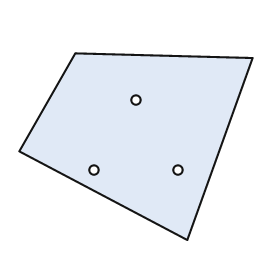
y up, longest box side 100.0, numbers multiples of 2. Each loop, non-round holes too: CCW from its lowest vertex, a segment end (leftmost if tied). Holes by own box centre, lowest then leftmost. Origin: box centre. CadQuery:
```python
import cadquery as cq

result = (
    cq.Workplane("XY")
    .moveTo(22.0, -40.0)
    .lineTo(50.0, 38.0)
    .lineTo(-26.0, 40.0)
    .lineTo(-50.0, -2.0)
    .close()
    .moveTo(-18.0, -10.0)
    .circle(2.0)
    .moveTo(18.0, -10.0)
    .circle(2.0)
    .moveTo(0.0, 20.0)
    .circle(2.0)
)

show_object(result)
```